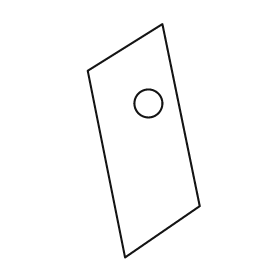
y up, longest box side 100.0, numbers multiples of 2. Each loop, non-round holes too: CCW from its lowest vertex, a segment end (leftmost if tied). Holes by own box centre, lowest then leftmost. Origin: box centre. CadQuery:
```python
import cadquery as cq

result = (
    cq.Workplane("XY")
    .moveTo(-8.0, -50.0)
    .lineTo(24.0, -28.0)
    .lineTo(8.0, 50.0)
    .lineTo(-24.0, 30.0)
    .close()
    .moveTo(2.0, 16.0)
    .circle(6.0)
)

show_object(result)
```